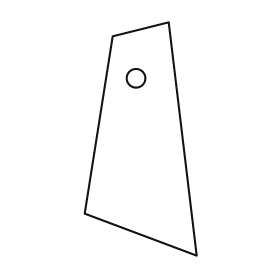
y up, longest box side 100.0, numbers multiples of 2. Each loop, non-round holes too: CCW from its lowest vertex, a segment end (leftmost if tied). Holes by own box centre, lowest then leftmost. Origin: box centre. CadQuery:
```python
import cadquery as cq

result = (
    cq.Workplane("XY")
    .moveTo(24.0, -50.0)
    .lineTo(12.0, 50.0)
    .lineTo(-12.0, 44.0)
    .lineTo(-24.0, -32.0)
    .close()
    .moveTo(-2.0, 26.0)
    .circle(4.0)
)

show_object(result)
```